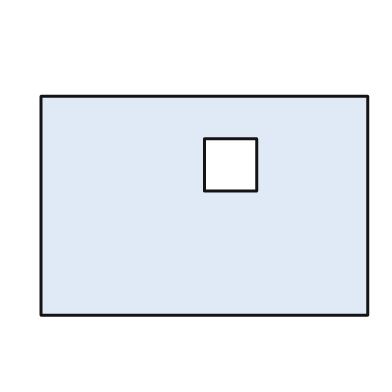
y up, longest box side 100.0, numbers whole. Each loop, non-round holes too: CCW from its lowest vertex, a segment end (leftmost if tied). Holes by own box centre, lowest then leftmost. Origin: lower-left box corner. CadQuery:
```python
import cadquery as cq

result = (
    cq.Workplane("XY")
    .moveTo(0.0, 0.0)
    .lineTo(100.0, 0.0)
    .lineTo(100.0, 67.0)
    .lineTo(0.0, 67.0)
    .close()
    .moveTo(50.0, 38.0)
    .lineTo(66.0, 38.0)
    .lineTo(66.0, 54.0)
    .lineTo(50.0, 54.0)
    .close()
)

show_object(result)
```